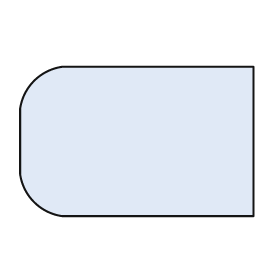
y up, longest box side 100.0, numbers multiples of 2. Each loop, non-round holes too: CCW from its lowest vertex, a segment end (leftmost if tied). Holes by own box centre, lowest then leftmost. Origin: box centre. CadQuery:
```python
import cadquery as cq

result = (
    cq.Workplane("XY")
    .moveTo(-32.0, -32.0)
    .lineTo(50.0, -32.0)
    .lineTo(50.0, 32.0)
    .lineTo(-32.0, 32.0)
    .threePointArc((-44.0, 26.0), (-50.0, 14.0))
    .lineTo(-50.0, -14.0)
    .threePointArc((-44.0, -26.0), (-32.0, -32.0))
    .close()
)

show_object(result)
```